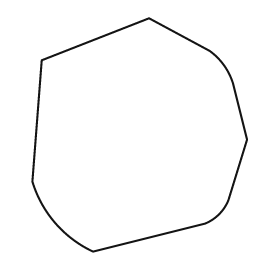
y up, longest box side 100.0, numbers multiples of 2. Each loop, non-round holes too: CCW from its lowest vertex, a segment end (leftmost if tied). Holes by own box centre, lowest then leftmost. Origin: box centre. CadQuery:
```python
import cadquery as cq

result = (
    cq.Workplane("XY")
    .moveTo(-20.0, -50.0)
    .lineTo(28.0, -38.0)
    .threePointArc((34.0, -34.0), (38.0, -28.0))
    .lineTo(46.0, -2.0)
    .lineTo(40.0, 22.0)
    .threePointArc((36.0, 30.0), (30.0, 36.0))
    .lineTo(4.0, 50.0)
    .lineTo(-42.0, 32.0)
    .lineTo(-46.0, -20.0)
    .threePointArc((-36.0, -38.0), (-20.0, -50.0))
    .close()
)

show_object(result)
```